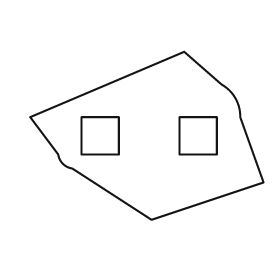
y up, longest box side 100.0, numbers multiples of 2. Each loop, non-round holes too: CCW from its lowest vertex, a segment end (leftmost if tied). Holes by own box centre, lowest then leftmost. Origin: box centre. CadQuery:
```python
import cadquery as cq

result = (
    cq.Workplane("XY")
    .moveTo(2.0, -36.0)
    .lineTo(50.0, -20.0)
    .lineTo(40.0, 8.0)
    .threePointArc((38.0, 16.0), (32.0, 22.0))
    .lineTo(16.0, 36.0)
    .lineTo(-50.0, 8.0)
    .lineTo(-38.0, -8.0)
    .threePointArc((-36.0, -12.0), (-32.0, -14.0))
    .close()
    .moveTo(-28.0, -8.0)
    .lineTo(-12.0, -8.0)
    .lineTo(-12.0, 8.0)
    .lineTo(-28.0, 8.0)
    .close()
    .moveTo(14.0, -8.0)
    .lineTo(30.0, -8.0)
    .lineTo(30.0, 8.0)
    .lineTo(14.0, 8.0)
    .close()
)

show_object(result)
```